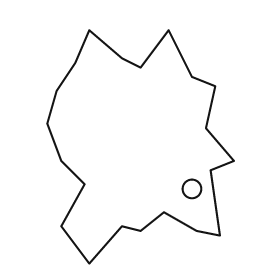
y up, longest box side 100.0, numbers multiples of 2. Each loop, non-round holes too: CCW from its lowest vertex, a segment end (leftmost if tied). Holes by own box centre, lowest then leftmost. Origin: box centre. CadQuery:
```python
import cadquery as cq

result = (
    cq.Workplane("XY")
    .moveTo(-22.0, -50.0)
    .lineTo(-8.0, -34.0)
    .lineTo(0.0, -36.0)
    .lineTo(10.0, -28.0)
    .lineTo(24.0, -36.0)
    .lineTo(34.0, -38.0)
    .lineTo(30.0, -10.0)
    .lineTo(40.0, -6.0)
    .lineTo(28.0, 8.0)
    .lineTo(32.0, 26.0)
    .lineTo(22.0, 30.0)
    .lineTo(12.0, 50.0)
    .lineTo(0.0, 34.0)
    .lineTo(-8.0, 38.0)
    .lineTo(-22.0, 50.0)
    .lineTo(-28.0, 36.0)
    .lineTo(-36.0, 24.0)
    .lineTo(-40.0, 10.0)
    .lineTo(-34.0, -6.0)
    .lineTo(-24.0, -16.0)
    .lineTo(-34.0, -34.0)
    .close()
    .moveTo(22.0, -18.0)
    .circle(4.0)
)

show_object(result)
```